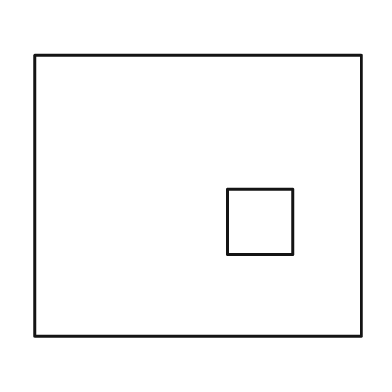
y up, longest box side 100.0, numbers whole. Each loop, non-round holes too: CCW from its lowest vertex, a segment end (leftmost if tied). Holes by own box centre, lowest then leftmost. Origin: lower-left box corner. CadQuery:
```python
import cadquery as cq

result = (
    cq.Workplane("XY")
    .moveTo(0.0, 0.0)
    .lineTo(100.0, 0.0)
    .lineTo(100.0, 86.0)
    .lineTo(0.0, 86.0)
    .close()
    .moveTo(59.0, 25.0)
    .lineTo(79.0, 25.0)
    .lineTo(79.0, 45.0)
    .lineTo(59.0, 45.0)
    .close()
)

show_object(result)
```